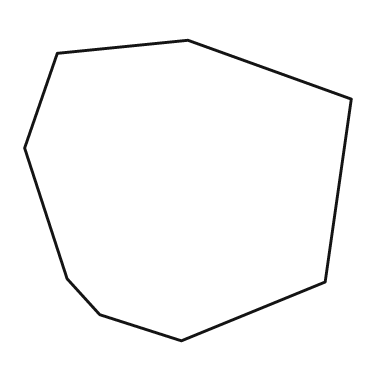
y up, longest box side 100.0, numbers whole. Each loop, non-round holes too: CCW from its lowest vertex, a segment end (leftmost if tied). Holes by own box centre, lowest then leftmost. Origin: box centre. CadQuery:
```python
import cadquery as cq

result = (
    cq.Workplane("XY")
    .moveTo(-2.0, -46.0)
    .lineTo(42.0, -28.0)
    .lineTo(50.0, 28.0)
    .lineTo(0.0, 46.0)
    .lineTo(-40.0, 42.0)
    .lineTo(-50.0, 13.0)
    .lineTo(-37.0, -27.0)
    .lineTo(-27.0, -38.0)
    .close()
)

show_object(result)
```